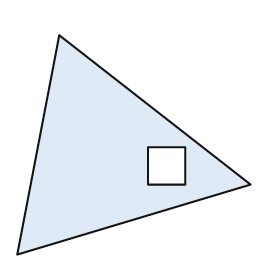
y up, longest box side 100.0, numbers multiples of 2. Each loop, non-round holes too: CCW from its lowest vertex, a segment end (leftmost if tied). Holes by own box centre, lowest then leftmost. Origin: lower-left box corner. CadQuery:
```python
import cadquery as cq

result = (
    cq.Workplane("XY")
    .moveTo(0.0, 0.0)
    .lineTo(100.0, 30.0)
    .lineTo(18.0, 94.0)
    .close()
    .moveTo(56.0, 30.0)
    .lineTo(72.0, 30.0)
    .lineTo(72.0, 46.0)
    .lineTo(56.0, 46.0)
    .close()
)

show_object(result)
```